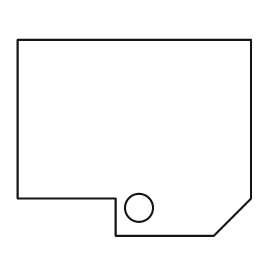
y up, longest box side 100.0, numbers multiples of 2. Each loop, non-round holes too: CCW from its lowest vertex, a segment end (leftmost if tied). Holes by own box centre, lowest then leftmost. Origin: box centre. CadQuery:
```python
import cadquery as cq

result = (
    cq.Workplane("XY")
    .moveTo(-8.0, -42.0)
    .lineTo(34.0, -42.0)
    .lineTo(50.0, -26.0)
    .lineTo(50.0, 42.0)
    .lineTo(-50.0, 42.0)
    .lineTo(-50.0, -26.0)
    .lineTo(-8.0, -26.0)
    .close()
    .moveTo(2.0, -30.0)
    .circle(6.0)
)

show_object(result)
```